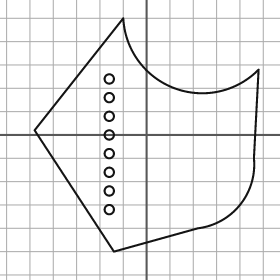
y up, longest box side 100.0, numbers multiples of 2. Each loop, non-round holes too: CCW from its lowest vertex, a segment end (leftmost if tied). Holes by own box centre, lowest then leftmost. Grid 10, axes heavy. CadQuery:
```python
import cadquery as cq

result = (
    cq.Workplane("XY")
    .moveTo(-14.0, -50.0)
    .lineTo(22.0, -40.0)
    .threePointArc((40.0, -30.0), (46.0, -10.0))
    .lineTo(48.0, 28.0)
    .threePointArc((12.0, 20.0), (-10.0, 50.0))
    .lineTo(-48.0, 2.0)
    .close()
    .moveTo(-16.0, -32.0)
    .circle(2.0)
    .moveTo(-16.0, -24.0)
    .circle(2.0)
    .moveTo(-16.0, -16.0)
    .circle(2.0)
    .moveTo(-16.0, -8.0)
    .circle(2.0)
    .moveTo(-16.0, 0.0)
    .circle(2.0)
    .moveTo(-16.0, 8.0)
    .circle(2.0)
    .moveTo(-16.0, 16.0)
    .circle(2.0)
    .moveTo(-16.0, 24.0)
    .circle(2.0)
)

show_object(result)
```